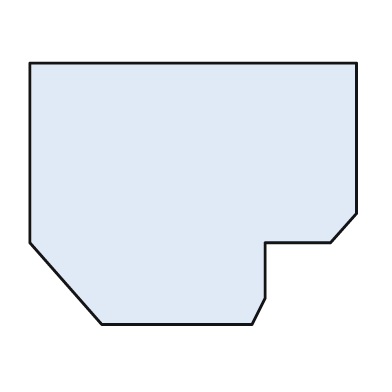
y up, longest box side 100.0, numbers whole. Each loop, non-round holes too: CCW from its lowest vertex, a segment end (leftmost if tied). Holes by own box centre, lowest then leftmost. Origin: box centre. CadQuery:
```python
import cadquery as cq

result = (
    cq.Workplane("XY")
    .moveTo(-28.0, -40.0)
    .lineTo(18.0, -40.0)
    .lineTo(22.0, -32.0)
    .lineTo(22.0, -15.0)
    .lineTo(42.0, -15.0)
    .lineTo(50.0, -6.0)
    .lineTo(50.0, 40.0)
    .lineTo(-50.0, 40.0)
    .lineTo(-50.0, -15.0)
    .close()
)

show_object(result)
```